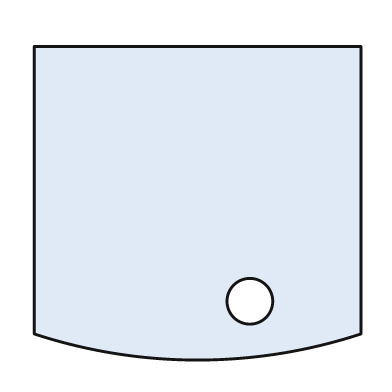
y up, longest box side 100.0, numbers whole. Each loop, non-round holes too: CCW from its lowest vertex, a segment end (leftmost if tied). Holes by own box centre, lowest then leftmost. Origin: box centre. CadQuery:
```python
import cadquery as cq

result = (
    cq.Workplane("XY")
    .moveTo(-50.0, -40.0)
    .threePointArc((0.0, -48.0), (50.0, -40.0))
    .lineTo(50.0, 48.0)
    .lineTo(-50.0, 48.0)
    .close()
    .moveTo(16.0, -30.0)
    .circle(7.0)
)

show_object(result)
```